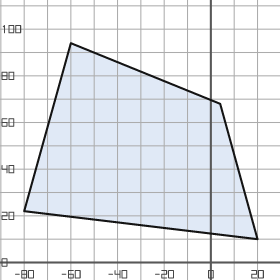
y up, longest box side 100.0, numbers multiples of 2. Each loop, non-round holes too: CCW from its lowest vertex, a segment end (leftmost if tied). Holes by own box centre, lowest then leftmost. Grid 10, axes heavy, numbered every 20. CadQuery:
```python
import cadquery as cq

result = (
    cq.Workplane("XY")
    .moveTo(20.0, 10.0)
    .lineTo(4.0, 68.0)
    .lineTo(-60.0, 94.0)
    .lineTo(-80.0, 22.0)
    .close()
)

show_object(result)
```